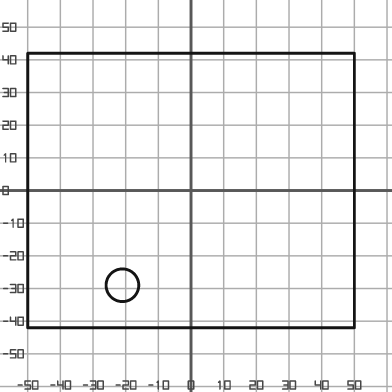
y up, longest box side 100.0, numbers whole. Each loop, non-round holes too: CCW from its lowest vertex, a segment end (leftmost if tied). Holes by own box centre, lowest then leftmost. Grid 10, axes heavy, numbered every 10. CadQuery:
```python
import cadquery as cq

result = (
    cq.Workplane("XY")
    .moveTo(-50.0, -42.0)
    .lineTo(50.0, -42.0)
    .lineTo(50.0, 42.0)
    .lineTo(-50.0, 42.0)
    .close()
    .moveTo(-21.0, -29.0)
    .circle(5.0)
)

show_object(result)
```